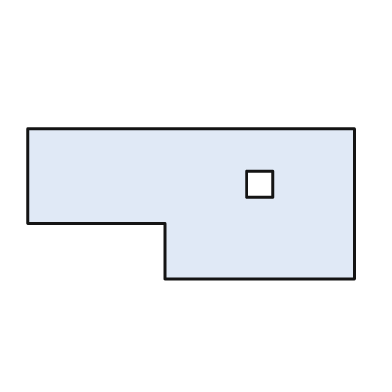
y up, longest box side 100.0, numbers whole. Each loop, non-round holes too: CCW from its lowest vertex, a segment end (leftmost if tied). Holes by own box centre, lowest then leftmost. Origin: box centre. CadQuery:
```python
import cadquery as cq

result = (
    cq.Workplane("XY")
    .moveTo(-8.0, -23.0)
    .lineTo(50.0, -23.0)
    .lineTo(50.0, 23.0)
    .lineTo(-50.0, 23.0)
    .lineTo(-50.0, -6.0)
    .lineTo(-8.0, -6.0)
    .close()
    .moveTo(17.0, 2.0)
    .lineTo(25.0, 2.0)
    .lineTo(25.0, 10.0)
    .lineTo(17.0, 10.0)
    .close()
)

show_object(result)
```